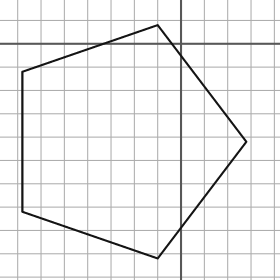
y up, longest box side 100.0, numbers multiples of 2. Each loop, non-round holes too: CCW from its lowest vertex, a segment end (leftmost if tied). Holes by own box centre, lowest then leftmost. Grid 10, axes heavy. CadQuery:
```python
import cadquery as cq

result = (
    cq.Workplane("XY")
    .moveTo(-10.0, -92.0)
    .lineTo(28.0, -42.0)
    .lineTo(-10.0, 8.0)
    .lineTo(-68.0, -12.0)
    .lineTo(-68.0, -72.0)
    .close()
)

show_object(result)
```